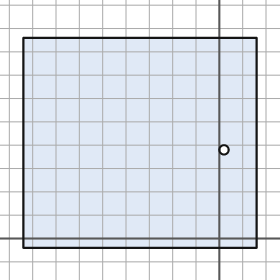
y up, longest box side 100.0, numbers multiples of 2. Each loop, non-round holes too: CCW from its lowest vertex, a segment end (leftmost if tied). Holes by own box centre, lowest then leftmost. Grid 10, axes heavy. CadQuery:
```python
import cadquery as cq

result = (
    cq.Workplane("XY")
    .moveTo(-84.0, -4.0)
    .lineTo(16.0, -4.0)
    .lineTo(16.0, 86.0)
    .lineTo(-84.0, 86.0)
    .close()
    .moveTo(2.0, 38.0)
    .circle(2.0)
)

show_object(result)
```